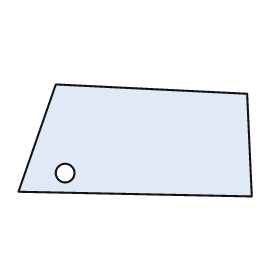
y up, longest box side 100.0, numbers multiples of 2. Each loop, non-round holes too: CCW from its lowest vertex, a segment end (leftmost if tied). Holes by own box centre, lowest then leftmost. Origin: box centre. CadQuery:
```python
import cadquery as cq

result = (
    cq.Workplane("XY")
    .moveTo(50.0, -24.0)
    .lineTo(48.0, 20.0)
    .lineTo(-34.0, 24.0)
    .lineTo(-50.0, -22.0)
    .close()
    .moveTo(-30.0, -14.0)
    .circle(4.0)
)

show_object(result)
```